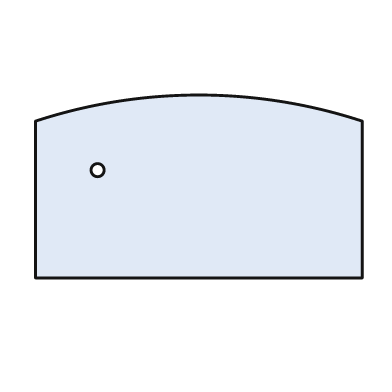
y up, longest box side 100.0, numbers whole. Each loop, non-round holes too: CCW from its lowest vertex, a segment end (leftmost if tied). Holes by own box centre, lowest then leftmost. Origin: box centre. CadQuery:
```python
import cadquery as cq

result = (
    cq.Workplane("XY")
    .moveTo(-50.0, -28.0)
    .lineTo(50.0, -28.0)
    .lineTo(50.0, 20.0)
    .threePointArc((0.0, 28.0), (-50.0, 20.0))
    .close()
    .moveTo(-31.0, 5.0)
    .circle(2.0)
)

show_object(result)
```